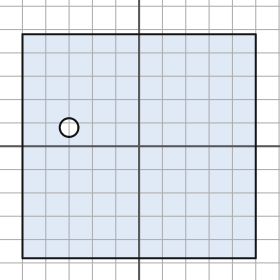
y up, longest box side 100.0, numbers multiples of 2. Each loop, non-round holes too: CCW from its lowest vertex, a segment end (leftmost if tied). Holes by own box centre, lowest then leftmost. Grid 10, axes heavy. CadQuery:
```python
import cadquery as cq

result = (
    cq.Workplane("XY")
    .moveTo(-50.0, -48.0)
    .lineTo(50.0, -48.0)
    .lineTo(50.0, 48.0)
    .lineTo(-50.0, 48.0)
    .close()
    .moveTo(-30.0, 8.0)
    .circle(4.0)
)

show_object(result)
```